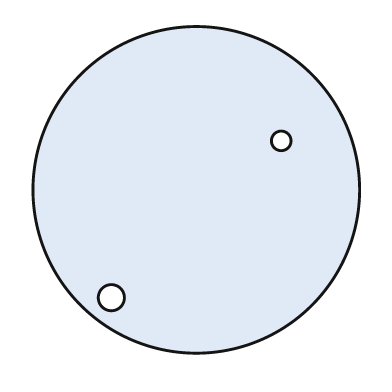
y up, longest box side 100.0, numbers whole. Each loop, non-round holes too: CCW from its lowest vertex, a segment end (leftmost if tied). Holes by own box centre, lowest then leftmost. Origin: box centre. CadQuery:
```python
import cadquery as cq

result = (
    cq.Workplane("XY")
    .moveTo(0.0, 0.0)
    .circle(50.0)
    .moveTo(-26.0, -33.0)
    .circle(4.0)
    .moveTo(26.0, 15.0)
    .circle(3.0)
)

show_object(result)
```